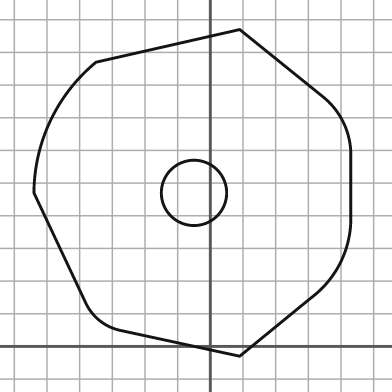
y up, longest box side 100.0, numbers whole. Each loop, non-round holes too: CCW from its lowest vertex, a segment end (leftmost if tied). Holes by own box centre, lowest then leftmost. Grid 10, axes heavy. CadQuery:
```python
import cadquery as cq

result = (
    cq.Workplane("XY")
    .moveTo(9.0, -3.0)
    .lineTo(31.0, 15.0)
    .threePointArc((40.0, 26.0), (43.0, 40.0))
    .lineTo(43.0, 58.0)
    .threePointArc((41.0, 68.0), (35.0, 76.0))
    .lineTo(9.0, 97.0)
    .lineTo(-35.0, 87.0)
    .threePointArc((-49.0, 69.0), (-54.0, 47.0))
    .lineTo(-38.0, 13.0)
    .threePointArc((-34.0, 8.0), (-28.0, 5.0))
    .close()
    .moveTo(-5.0, 47.0)
    .circle(10.0)
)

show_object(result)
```